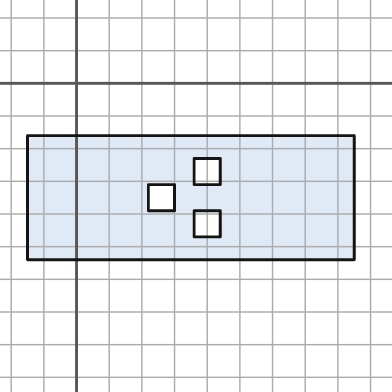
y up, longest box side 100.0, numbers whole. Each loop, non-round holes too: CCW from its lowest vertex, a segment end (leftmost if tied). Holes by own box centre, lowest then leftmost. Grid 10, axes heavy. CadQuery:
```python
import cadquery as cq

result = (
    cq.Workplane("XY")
    .moveTo(-15.0, -54.0)
    .lineTo(85.0, -54.0)
    .lineTo(85.0, -16.0)
    .lineTo(-15.0, -16.0)
    .close()
    .moveTo(36.0, -47.0)
    .lineTo(44.0, -47.0)
    .lineTo(44.0, -39.0)
    .lineTo(36.0, -39.0)
    .close()
    .moveTo(22.0, -39.0)
    .lineTo(30.0, -39.0)
    .lineTo(30.0, -31.0)
    .lineTo(22.0, -31.0)
    .close()
    .moveTo(36.0, -31.0)
    .lineTo(44.0, -31.0)
    .lineTo(44.0, -23.0)
    .lineTo(36.0, -23.0)
    .close()
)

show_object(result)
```